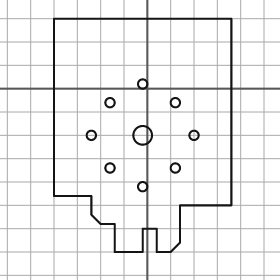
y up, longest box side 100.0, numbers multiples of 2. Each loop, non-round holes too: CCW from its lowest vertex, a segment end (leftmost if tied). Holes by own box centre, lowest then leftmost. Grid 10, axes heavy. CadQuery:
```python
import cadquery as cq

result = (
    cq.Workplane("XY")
    .moveTo(-14.0, -70.0)
    .lineTo(-2.0, -70.0)
    .lineTo(-2.0, -60.0)
    .lineTo(4.0, -60.0)
    .lineTo(4.0, -70.0)
    .lineTo(10.0, -70.0)
    .lineTo(14.0, -66.0)
    .lineTo(14.0, -50.0)
    .lineTo(36.0, -50.0)
    .lineTo(36.0, 30.0)
    .lineTo(-40.0, 30.0)
    .lineTo(-40.0, -46.0)
    .lineTo(-24.0, -46.0)
    .lineTo(-24.0, -54.0)
    .lineTo(-20.0, -58.0)
    .lineTo(-14.0, -58.0)
    .close()
    .moveTo(-2.0, -42.0)
    .circle(2.0)
    .moveTo(-16.0, -34.0)
    .circle(2.0)
    .moveTo(12.0, -34.0)
    .circle(2.0)
    .moveTo(-24.0, -20.0)
    .circle(2.0)
    .moveTo(-2.0, -20.0)
    .circle(4.0)
    .moveTo(20.0, -20.0)
    .circle(2.0)
    .moveTo(-16.0, -6.0)
    .circle(2.0)
    .moveTo(12.0, -6.0)
    .circle(2.0)
    .moveTo(-2.0, 2.0)
    .circle(2.0)
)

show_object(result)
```